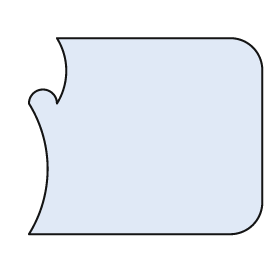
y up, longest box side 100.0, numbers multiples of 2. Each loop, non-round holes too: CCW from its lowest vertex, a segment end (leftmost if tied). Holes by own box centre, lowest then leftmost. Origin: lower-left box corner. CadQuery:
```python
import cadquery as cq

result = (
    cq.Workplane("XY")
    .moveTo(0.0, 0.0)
    .lineTo(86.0, 0.0)
    .threePointArc((96.0, 4.0), (100.0, 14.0))
    .lineTo(100.0, 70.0)
    .threePointArc((96.0, 80.0), (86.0, 84.0))
    .lineTo(12.0, 84.0)
    .threePointArc((16.0, 70.0), (12.0, 56.0))
    .threePointArc((6.0, 62.0), (0.0, 56.0))
    .threePointArc((8.0, 28.0), (0.0, 0.0))
    .close()
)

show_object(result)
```